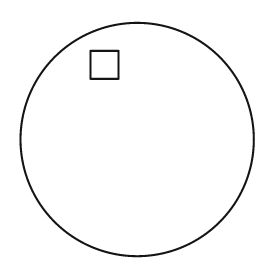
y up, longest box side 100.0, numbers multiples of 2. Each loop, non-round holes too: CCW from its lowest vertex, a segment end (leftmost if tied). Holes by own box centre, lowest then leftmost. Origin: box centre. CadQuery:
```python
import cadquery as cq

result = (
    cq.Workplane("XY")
    .moveTo(0.0, 0.0)
    .circle(50.0)
    .moveTo(-20.0, 26.0)
    .lineTo(-8.0, 26.0)
    .lineTo(-8.0, 38.0)
    .lineTo(-20.0, 38.0)
    .close()
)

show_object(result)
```